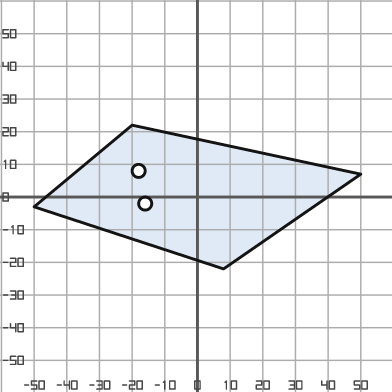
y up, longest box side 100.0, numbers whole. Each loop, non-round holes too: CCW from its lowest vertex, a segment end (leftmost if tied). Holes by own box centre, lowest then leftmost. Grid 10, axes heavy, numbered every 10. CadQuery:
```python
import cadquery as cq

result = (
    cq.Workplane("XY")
    .moveTo(8.0, -22.0)
    .lineTo(50.0, 7.0)
    .lineTo(-20.0, 22.0)
    .lineTo(-50.0, -3.0)
    .close()
    .moveTo(-16.0, -2.0)
    .circle(2.0)
    .moveTo(-18.0, 8.0)
    .circle(2.0)
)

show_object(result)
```